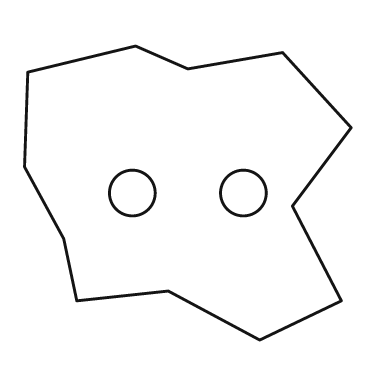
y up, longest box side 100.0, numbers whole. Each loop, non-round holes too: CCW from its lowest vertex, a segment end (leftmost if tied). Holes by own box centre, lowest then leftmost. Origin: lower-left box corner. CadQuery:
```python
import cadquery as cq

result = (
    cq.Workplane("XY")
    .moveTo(72.0, 0.0)
    .lineTo(97.0, 12.0)
    .lineTo(82.0, 41.0)
    .lineTo(100.0, 65.0)
    .lineTo(79.0, 88.0)
    .lineTo(50.0, 83.0)
    .lineTo(34.0, 90.0)
    .lineTo(1.0, 82.0)
    .lineTo(0.0, 53.0)
    .lineTo(12.0, 31.0)
    .lineTo(16.0, 12.0)
    .lineTo(44.0, 15.0)
    .close()
    .moveTo(33.0, 45.0)
    .circle(7.0)
    .moveTo(67.0, 45.0)
    .circle(7.0)
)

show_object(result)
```